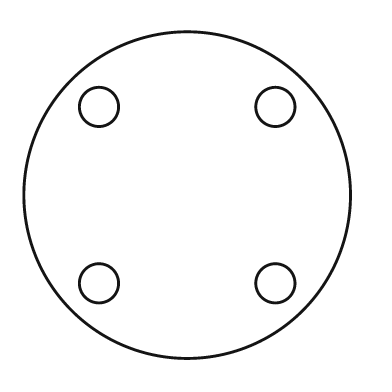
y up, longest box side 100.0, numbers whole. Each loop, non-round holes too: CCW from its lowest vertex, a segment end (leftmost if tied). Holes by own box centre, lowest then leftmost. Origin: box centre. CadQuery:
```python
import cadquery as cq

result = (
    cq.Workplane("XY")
    .moveTo(0.0, 0.0)
    .circle(50.0)
    .moveTo(-27.0, -27.0)
    .circle(6.0)
    .moveTo(27.0, -27.0)
    .circle(6.0)
    .moveTo(-27.0, 27.0)
    .circle(6.0)
    .moveTo(27.0, 27.0)
    .circle(6.0)
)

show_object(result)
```